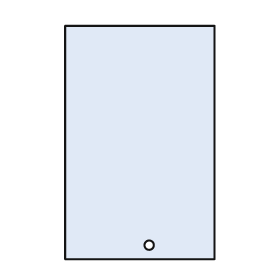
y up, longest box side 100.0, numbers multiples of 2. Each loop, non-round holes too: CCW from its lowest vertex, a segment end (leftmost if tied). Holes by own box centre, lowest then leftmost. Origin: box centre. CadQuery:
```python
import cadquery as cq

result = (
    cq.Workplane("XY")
    .moveTo(-32.0, -50.0)
    .lineTo(32.0, -50.0)
    .lineTo(32.0, 50.0)
    .lineTo(-32.0, 50.0)
    .close()
    .moveTo(4.0, -44.0)
    .circle(2.0)
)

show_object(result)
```